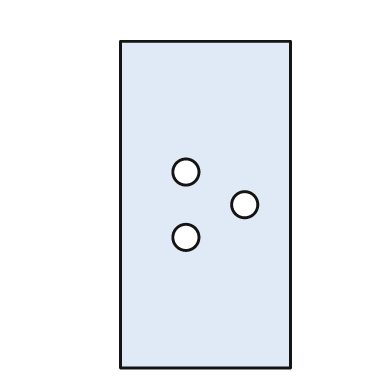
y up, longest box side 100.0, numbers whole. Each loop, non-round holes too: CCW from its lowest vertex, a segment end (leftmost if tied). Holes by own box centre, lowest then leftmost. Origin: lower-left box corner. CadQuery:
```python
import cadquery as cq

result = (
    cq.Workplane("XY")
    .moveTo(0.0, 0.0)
    .lineTo(52.0, 0.0)
    .lineTo(52.0, 100.0)
    .lineTo(0.0, 100.0)
    .close()
    .moveTo(20.0, 40.0)
    .circle(4.0)
    .moveTo(38.0, 50.0)
    .circle(4.0)
    .moveTo(20.0, 60.0)
    .circle(4.0)
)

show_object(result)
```